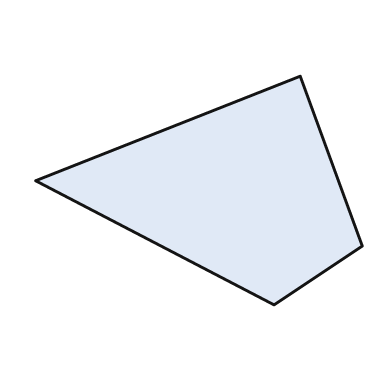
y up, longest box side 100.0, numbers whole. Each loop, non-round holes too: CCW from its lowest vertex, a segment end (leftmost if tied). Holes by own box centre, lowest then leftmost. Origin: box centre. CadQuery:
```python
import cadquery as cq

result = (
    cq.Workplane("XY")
    .moveTo(23.0, -35.0)
    .lineTo(50.0, -17.0)
    .lineTo(31.0, 35.0)
    .lineTo(-50.0, 3.0)
    .close()
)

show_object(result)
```